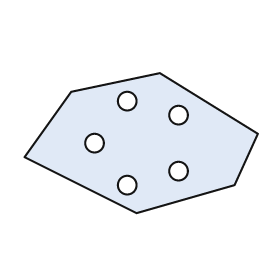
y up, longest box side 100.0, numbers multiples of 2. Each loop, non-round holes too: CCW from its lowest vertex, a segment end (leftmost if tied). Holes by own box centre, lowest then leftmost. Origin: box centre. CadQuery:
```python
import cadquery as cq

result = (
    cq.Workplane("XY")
    .moveTo(-2.0, -30.0)
    .lineTo(40.0, -18.0)
    .lineTo(50.0, 4.0)
    .lineTo(8.0, 30.0)
    .lineTo(-30.0, 22.0)
    .lineTo(-50.0, -6.0)
    .close()
    .moveTo(-6.0, -18.0)
    .circle(4.0)
    .moveTo(16.0, -12.0)
    .circle(4.0)
    .moveTo(-20.0, 0.0)
    .circle(4.0)
    .moveTo(16.0, 12.0)
    .circle(4.0)
    .moveTo(-6.0, 18.0)
    .circle(4.0)
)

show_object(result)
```